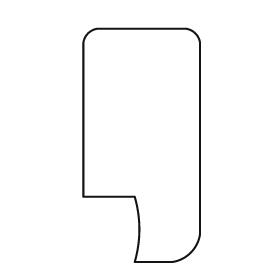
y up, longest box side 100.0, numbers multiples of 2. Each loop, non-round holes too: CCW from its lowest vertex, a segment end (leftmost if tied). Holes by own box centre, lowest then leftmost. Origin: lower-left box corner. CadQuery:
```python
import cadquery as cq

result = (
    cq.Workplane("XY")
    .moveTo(22.0, 0.0)
    .lineTo(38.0, 0.0)
    .threePointArc((46.0, 4.0), (50.0, 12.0))
    .lineTo(50.0, 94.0)
    .threePointArc((48.0, 98.0), (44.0, 100.0))
    .lineTo(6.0, 100.0)
    .threePointArc((2.0, 98.0), (0.0, 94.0))
    .lineTo(0.0, 28.0)
    .lineTo(22.0, 28.0)
    .threePointArc((24.0, 14.0), (22.0, 0.0))
    .close()
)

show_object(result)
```